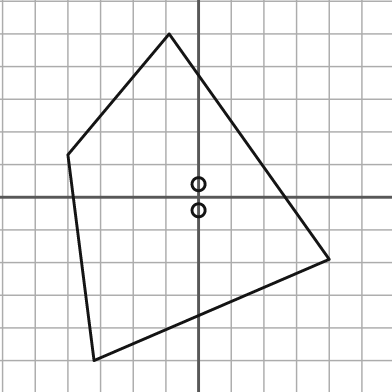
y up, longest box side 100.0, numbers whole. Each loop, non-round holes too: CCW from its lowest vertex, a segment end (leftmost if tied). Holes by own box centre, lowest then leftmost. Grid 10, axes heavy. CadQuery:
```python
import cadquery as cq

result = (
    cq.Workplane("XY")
    .moveTo(-32.0, -50.0)
    .lineTo(40.0, -19.0)
    .lineTo(-9.0, 50.0)
    .lineTo(-40.0, 13.0)
    .close()
    .moveTo(0.0, -4.0)
    .circle(2.0)
    .moveTo(0.0, 4.0)
    .circle(2.0)
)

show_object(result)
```